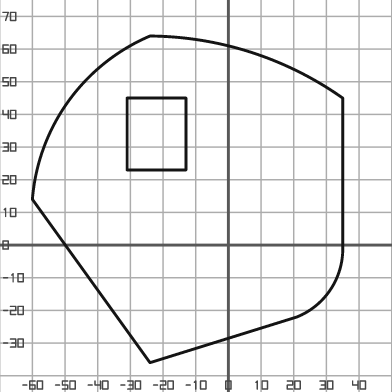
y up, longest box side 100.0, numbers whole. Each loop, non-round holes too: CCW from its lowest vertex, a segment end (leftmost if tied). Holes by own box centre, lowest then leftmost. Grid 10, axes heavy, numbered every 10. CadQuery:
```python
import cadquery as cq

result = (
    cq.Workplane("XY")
    .moveTo(-24.0, -36.0)
    .lineTo(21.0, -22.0)
    .threePointArc((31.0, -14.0), (35.0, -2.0))
    .lineTo(35.0, 45.0)
    .threePointArc((7.0, 59.0), (-24.0, 64.0))
    .threePointArc((-49.0, 44.0), (-60.0, 14.0))
    .close()
    .moveTo(-31.0, 23.0)
    .lineTo(-13.0, 23.0)
    .lineTo(-13.0, 45.0)
    .lineTo(-31.0, 45.0)
    .close()
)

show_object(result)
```